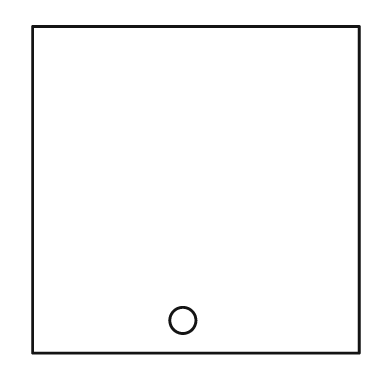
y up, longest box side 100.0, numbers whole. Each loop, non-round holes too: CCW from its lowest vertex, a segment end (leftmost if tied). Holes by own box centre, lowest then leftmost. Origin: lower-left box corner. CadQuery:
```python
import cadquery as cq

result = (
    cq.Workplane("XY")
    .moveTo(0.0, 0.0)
    .lineTo(100.0, 0.0)
    .lineTo(100.0, 100.0)
    .lineTo(0.0, 100.0)
    .close()
    .moveTo(46.0, 10.0)
    .circle(4.0)
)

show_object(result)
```